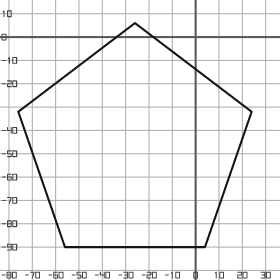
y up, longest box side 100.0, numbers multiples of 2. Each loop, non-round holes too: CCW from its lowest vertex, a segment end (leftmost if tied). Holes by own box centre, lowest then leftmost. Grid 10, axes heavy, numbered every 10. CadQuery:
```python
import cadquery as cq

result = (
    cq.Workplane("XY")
    .moveTo(-56.0, -90.0)
    .lineTo(4.0, -90.0)
    .lineTo(24.0, -32.0)
    .lineTo(-26.0, 6.0)
    .lineTo(-76.0, -32.0)
    .close()
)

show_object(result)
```